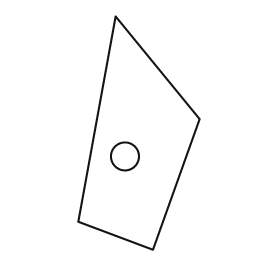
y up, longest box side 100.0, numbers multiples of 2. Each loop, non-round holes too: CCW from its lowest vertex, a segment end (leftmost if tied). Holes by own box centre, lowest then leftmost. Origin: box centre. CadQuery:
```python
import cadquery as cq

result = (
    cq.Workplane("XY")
    .moveTo(6.0, -50.0)
    .lineTo(26.0, 6.0)
    .lineTo(-10.0, 50.0)
    .lineTo(-26.0, -38.0)
    .close()
    .moveTo(-6.0, -10.0)
    .circle(6.0)
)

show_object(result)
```